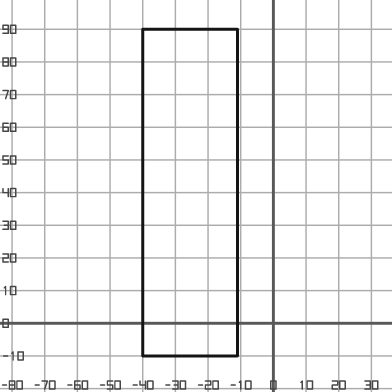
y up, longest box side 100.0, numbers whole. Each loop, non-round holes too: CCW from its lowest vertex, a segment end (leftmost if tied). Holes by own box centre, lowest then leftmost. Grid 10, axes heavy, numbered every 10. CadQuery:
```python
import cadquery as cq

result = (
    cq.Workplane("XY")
    .moveTo(-40.0, -10.0)
    .lineTo(-11.0, -10.0)
    .lineTo(-11.0, 90.0)
    .lineTo(-40.0, 90.0)
    .close()
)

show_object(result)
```